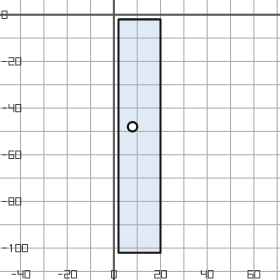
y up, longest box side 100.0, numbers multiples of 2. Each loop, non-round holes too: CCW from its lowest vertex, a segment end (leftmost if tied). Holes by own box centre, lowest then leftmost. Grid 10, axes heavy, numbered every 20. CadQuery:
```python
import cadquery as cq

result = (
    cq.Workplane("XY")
    .moveTo(2.0, -102.0)
    .lineTo(20.0, -102.0)
    .lineTo(20.0, -2.0)
    .lineTo(2.0, -2.0)
    .close()
    .moveTo(8.0, -48.0)
    .circle(2.0)
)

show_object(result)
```